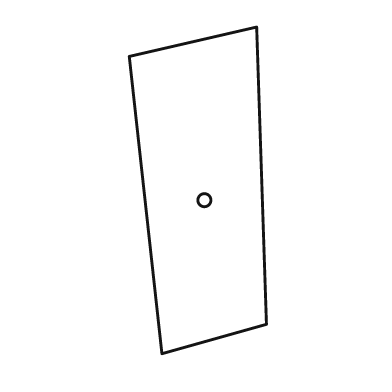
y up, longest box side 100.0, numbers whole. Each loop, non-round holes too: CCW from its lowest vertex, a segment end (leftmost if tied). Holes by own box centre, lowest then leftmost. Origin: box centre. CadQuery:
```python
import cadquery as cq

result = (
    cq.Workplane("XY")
    .moveTo(-11.0, -50.0)
    .lineTo(21.0, -41.0)
    .lineTo(18.0, 50.0)
    .lineTo(-21.0, 41.0)
    .close()
    .moveTo(2.0, -3.0)
    .circle(2.0)
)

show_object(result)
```